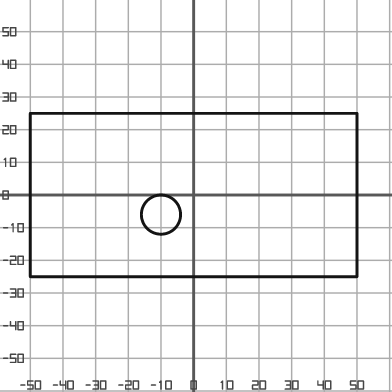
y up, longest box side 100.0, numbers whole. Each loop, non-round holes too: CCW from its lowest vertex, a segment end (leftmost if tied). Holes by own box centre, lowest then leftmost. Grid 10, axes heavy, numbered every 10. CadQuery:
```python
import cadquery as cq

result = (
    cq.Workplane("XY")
    .moveTo(-50.0, -25.0)
    .lineTo(50.0, -25.0)
    .lineTo(50.0, 25.0)
    .lineTo(-50.0, 25.0)
    .close()
    .moveTo(-10.0, -6.0)
    .circle(6.0)
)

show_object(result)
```